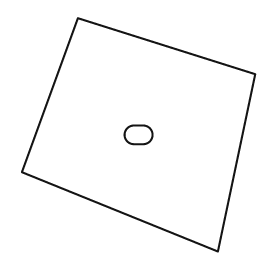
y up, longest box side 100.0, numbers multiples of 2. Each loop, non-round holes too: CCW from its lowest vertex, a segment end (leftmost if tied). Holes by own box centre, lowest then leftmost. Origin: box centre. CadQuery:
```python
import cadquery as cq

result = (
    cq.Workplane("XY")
    .moveTo(34.0, -50.0)
    .lineTo(50.0, 26.0)
    .lineTo(-26.0, 50.0)
    .lineTo(-50.0, -16.0)
    .close()
    .moveTo(-2.0, -4.0)
    .lineTo(2.0, -4.0)
    .threePointArc((6.0, 0.0), (2.0, 4.0))
    .lineTo(-2.0, 4.0)
    .threePointArc((-6.0, 0.0), (-2.0, -4.0))
    .close()
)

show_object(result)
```